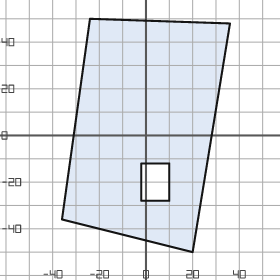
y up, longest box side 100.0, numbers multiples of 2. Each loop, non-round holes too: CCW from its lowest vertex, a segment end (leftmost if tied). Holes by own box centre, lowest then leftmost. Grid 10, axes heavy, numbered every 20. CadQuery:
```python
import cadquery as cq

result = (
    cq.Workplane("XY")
    .moveTo(20.0, -50.0)
    .lineTo(36.0, 48.0)
    .lineTo(-24.0, 50.0)
    .lineTo(-36.0, -36.0)
    .close()
    .moveTo(-2.0, -28.0)
    .lineTo(10.0, -28.0)
    .lineTo(10.0, -12.0)
    .lineTo(-2.0, -12.0)
    .close()
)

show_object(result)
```